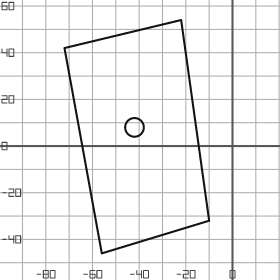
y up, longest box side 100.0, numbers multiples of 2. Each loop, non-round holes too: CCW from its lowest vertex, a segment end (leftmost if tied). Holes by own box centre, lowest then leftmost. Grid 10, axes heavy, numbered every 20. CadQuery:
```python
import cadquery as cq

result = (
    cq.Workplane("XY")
    .moveTo(-56.0, -46.0)
    .lineTo(-10.0, -32.0)
    .lineTo(-22.0, 54.0)
    .lineTo(-72.0, 42.0)
    .close()
    .moveTo(-42.0, 8.0)
    .circle(4.0)
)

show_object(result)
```